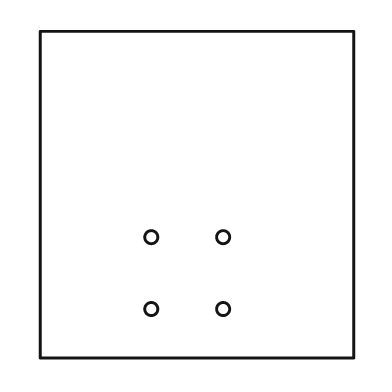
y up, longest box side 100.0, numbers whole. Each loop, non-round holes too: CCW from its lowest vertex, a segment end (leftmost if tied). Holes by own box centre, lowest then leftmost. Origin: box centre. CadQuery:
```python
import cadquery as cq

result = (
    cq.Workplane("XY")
    .moveTo(-48.0, -50.0)
    .lineTo(48.0, -50.0)
    .lineTo(48.0, 50.0)
    .lineTo(-48.0, 50.0)
    .close()
    .moveTo(-14.0, -35.0)
    .circle(2.0)
    .moveTo(8.0, -35.0)
    .circle(2.0)
    .moveTo(-14.0, -13.0)
    .circle(2.0)
    .moveTo(8.0, -13.0)
    .circle(2.0)
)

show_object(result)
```